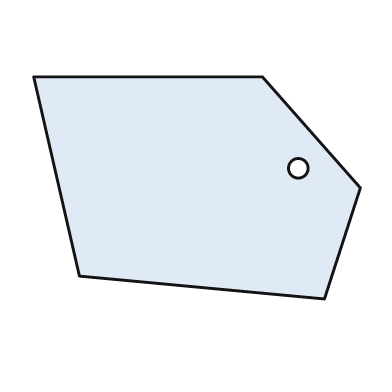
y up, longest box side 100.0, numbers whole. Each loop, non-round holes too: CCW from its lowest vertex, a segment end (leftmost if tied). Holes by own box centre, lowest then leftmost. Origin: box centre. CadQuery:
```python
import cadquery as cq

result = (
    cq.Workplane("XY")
    .moveTo(39.0, -34.0)
    .lineTo(50.0, 0.0)
    .lineTo(20.0, 34.0)
    .lineTo(-50.0, 34.0)
    .lineTo(-36.0, -27.0)
    .close()
    .moveTo(31.0, 6.0)
    .circle(3.0)
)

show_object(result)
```